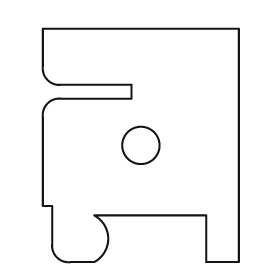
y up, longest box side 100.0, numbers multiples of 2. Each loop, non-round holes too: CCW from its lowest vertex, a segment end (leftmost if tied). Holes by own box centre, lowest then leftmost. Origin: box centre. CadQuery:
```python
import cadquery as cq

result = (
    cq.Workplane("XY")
    .moveTo(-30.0, -50.0)
    .lineTo(-20.0, -50.0)
    .threePointArc((-14.0, -40.0), (-20.0, -30.0))
    .lineTo(28.0, -30.0)
    .lineTo(28.0, -50.0)
    .lineTo(42.0, -50.0)
    .lineTo(42.0, 50.0)
    .lineTo(-42.0, 50.0)
    .lineTo(-42.0, 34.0)
    .threePointArc((-40.0, 28.0), (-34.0, 26.0))
    .lineTo(-4.0, 26.0)
    .lineTo(-4.0, 20.0)
    .lineTo(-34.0, 20.0)
    .threePointArc((-40.0, 18.0), (-42.0, 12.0))
    .lineTo(-42.0, -26.0)
    .lineTo(-38.0, -26.0)
    .lineTo(-38.0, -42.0)
    .threePointArc((-36.0, -48.0), (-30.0, -50.0))
    .close()
    .moveTo(0.0, 0.0)
    .circle(8.0)
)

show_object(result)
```